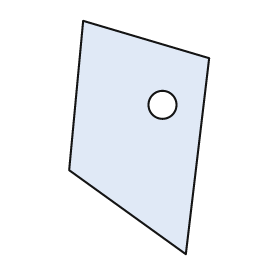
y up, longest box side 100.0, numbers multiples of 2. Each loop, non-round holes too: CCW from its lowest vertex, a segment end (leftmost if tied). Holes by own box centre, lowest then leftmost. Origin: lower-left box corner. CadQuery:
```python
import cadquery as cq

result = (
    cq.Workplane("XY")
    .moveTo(50.0, 0.0)
    .lineTo(60.0, 84.0)
    .lineTo(6.0, 100.0)
    .lineTo(0.0, 36.0)
    .close()
    .moveTo(40.0, 64.0)
    .circle(6.0)
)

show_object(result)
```